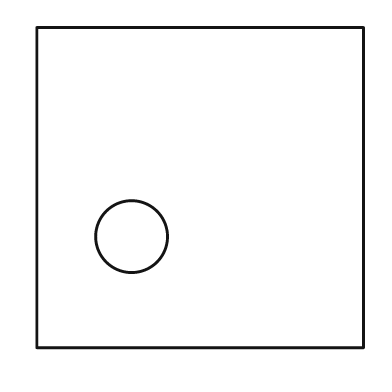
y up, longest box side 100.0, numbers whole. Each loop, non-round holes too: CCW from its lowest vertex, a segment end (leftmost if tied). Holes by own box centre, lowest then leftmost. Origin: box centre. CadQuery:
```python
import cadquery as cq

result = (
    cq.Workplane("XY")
    .moveTo(-50.0, -49.0)
    .lineTo(50.0, -49.0)
    .lineTo(50.0, 49.0)
    .lineTo(-50.0, 49.0)
    .close()
    .moveTo(-21.0, -15.0)
    .circle(11.0)
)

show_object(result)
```